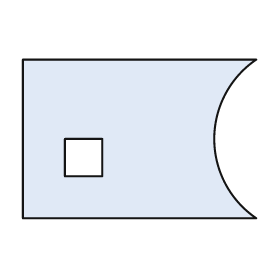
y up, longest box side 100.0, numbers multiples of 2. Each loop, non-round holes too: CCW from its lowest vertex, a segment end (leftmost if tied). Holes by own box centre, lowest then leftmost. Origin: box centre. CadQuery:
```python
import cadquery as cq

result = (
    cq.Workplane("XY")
    .moveTo(-50.0, -34.0)
    .lineTo(50.0, -34.0)
    .threePointArc((32.0, 0.0), (50.0, 34.0))
    .lineTo(-50.0, 34.0)
    .close()
    .moveTo(-32.0, -16.0)
    .lineTo(-16.0, -16.0)
    .lineTo(-16.0, 0.0)
    .lineTo(-32.0, 0.0)
    .close()
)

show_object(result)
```